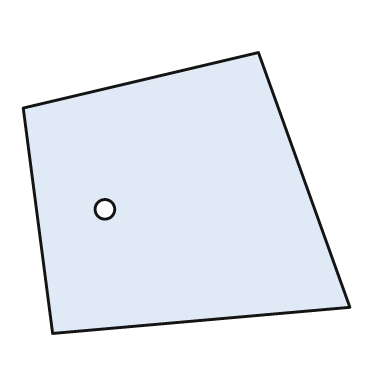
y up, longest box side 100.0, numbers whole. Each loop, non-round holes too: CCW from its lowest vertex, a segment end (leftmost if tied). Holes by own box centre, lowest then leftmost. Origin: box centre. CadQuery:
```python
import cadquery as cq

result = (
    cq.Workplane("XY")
    .moveTo(-41.0, -43.0)
    .lineTo(50.0, -35.0)
    .lineTo(22.0, 43.0)
    .lineTo(-50.0, 26.0)
    .close()
    .moveTo(-25.0, -5.0)
    .circle(3.0)
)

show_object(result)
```